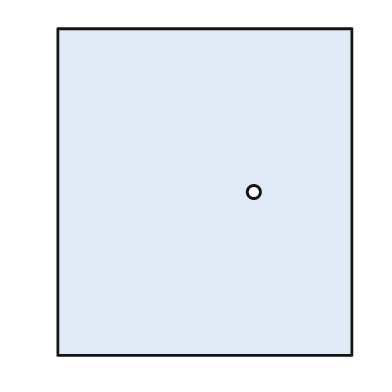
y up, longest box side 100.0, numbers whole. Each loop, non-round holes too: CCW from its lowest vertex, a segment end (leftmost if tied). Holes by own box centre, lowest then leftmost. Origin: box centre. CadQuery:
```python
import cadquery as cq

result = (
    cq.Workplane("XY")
    .moveTo(-45.0, -50.0)
    .lineTo(45.0, -50.0)
    .lineTo(45.0, 50.0)
    .lineTo(-45.0, 50.0)
    .close()
    .moveTo(15.0, 0.0)
    .circle(2.0)
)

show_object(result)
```